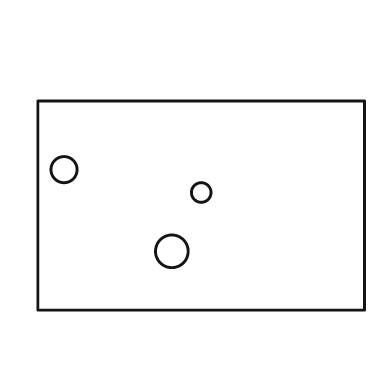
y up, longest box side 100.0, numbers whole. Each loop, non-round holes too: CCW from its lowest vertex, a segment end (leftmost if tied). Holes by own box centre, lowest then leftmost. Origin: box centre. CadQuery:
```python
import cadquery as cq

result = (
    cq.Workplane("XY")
    .moveTo(-50.0, -32.0)
    .lineTo(50.0, -32.0)
    .lineTo(50.0, 32.0)
    .lineTo(-50.0, 32.0)
    .close()
    .moveTo(-9.0, -14.0)
    .circle(5.0)
    .moveTo(0.0, 4.0)
    .circle(3.0)
    .moveTo(-42.0, 11.0)
    .circle(4.0)
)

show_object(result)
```